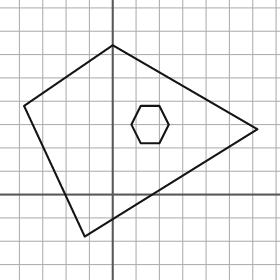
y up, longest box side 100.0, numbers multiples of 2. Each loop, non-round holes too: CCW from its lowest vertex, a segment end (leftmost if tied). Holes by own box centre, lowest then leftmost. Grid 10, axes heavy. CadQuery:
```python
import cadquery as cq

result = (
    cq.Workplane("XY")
    .moveTo(-12.0, -18.0)
    .lineTo(62.0, 28.0)
    .lineTo(0.0, 64.0)
    .lineTo(-38.0, 38.0)
    .close()
    .moveTo(12.0, 22.0)
    .lineTo(20.0, 22.0)
    .lineTo(24.0, 30.0)
    .lineTo(20.0, 38.0)
    .lineTo(12.0, 38.0)
    .lineTo(8.0, 30.0)
    .close()
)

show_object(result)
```